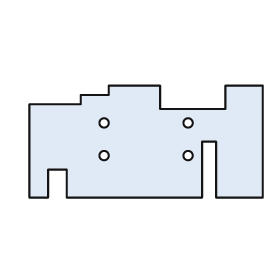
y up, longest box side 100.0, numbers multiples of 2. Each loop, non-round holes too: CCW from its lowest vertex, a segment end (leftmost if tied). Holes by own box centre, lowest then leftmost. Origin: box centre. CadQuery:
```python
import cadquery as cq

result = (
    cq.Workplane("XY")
    .moveTo(-50.0, -24.0)
    .lineTo(-42.0, -24.0)
    .lineTo(-42.0, -12.0)
    .lineTo(-34.0, -12.0)
    .lineTo(-34.0, -24.0)
    .lineTo(24.0, -24.0)
    .lineTo(24.0, 0.0)
    .lineTo(30.0, 0.0)
    .lineTo(30.0, -24.0)
    .lineTo(50.0, -24.0)
    .lineTo(50.0, 24.0)
    .lineTo(34.0, 24.0)
    .lineTo(34.0, 14.0)
    .lineTo(6.0, 14.0)
    .lineTo(6.0, 24.0)
    .lineTo(-16.0, 24.0)
    .lineTo(-16.0, 20.0)
    .lineTo(-28.0, 20.0)
    .lineTo(-28.0, 16.0)
    .lineTo(-50.0, 16.0)
    .close()
    .moveTo(-18.0, -6.0)
    .circle(2.0)
    .moveTo(18.0, -6.0)
    .circle(2.0)
    .moveTo(-18.0, 8.0)
    .circle(2.0)
    .moveTo(18.0, 8.0)
    .circle(2.0)
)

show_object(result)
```